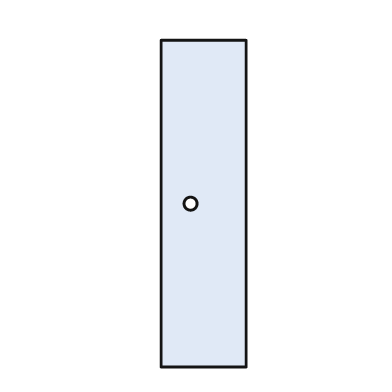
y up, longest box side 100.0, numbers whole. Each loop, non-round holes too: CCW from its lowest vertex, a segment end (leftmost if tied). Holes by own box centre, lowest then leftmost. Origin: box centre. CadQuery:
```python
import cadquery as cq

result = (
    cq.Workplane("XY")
    .moveTo(-13.0, -50.0)
    .lineTo(13.0, -50.0)
    .lineTo(13.0, 50.0)
    .lineTo(-13.0, 50.0)
    .close()
    .moveTo(-4.0, 0.0)
    .circle(2.0)
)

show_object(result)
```